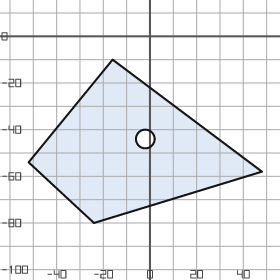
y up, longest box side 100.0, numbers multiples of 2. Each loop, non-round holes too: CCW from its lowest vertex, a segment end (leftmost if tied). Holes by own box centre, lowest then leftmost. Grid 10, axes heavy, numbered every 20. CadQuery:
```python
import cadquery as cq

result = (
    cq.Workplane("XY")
    .moveTo(-24.0, -80.0)
    .lineTo(48.0, -58.0)
    .lineTo(-16.0, -10.0)
    .lineTo(-52.0, -54.0)
    .close()
    .moveTo(-2.0, -44.0)
    .circle(4.0)
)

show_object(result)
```